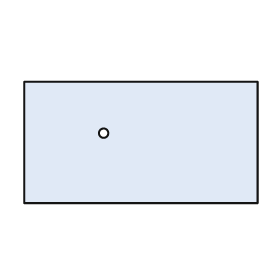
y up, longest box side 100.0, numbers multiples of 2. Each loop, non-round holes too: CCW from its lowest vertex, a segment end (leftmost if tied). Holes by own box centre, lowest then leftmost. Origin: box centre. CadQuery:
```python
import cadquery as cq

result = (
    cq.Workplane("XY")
    .moveTo(-50.0, -26.0)
    .lineTo(50.0, -26.0)
    .lineTo(50.0, 26.0)
    .lineTo(-50.0, 26.0)
    .close()
    .moveTo(-16.0, 4.0)
    .circle(2.0)
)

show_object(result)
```